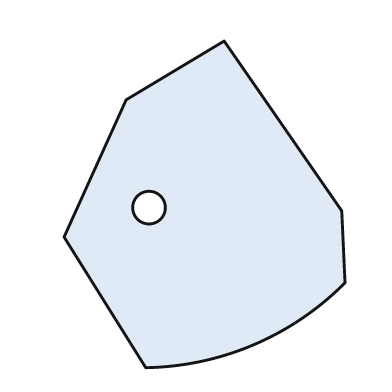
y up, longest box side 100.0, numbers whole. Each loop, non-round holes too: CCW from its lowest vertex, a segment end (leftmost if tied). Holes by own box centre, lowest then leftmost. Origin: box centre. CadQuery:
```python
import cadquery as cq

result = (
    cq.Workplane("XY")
    .moveTo(-18.0, -50.0)
    .threePointArc((15.0, -43.0), (43.0, -24.0))
    .lineTo(42.0, -2.0)
    .lineTo(6.0, 50.0)
    .lineTo(-24.0, 32.0)
    .lineTo(-43.0, -10.0)
    .close()
    .moveTo(-17.0, -1.0)
    .circle(5.0)
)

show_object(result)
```